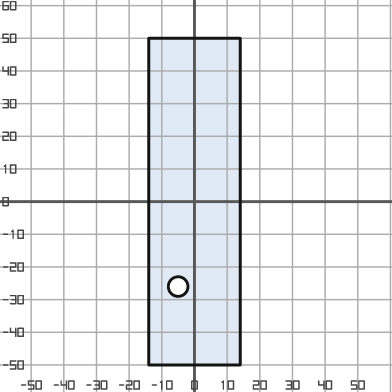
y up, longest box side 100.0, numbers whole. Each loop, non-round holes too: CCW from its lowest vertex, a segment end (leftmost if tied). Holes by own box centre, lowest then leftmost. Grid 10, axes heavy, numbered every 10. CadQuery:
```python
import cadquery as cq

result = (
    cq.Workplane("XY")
    .moveTo(-14.0, -50.0)
    .lineTo(14.0, -50.0)
    .lineTo(14.0, 50.0)
    .lineTo(-14.0, 50.0)
    .close()
    .moveTo(-5.0, -26.0)
    .circle(3.0)
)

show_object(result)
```